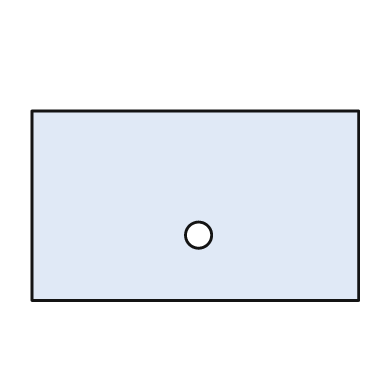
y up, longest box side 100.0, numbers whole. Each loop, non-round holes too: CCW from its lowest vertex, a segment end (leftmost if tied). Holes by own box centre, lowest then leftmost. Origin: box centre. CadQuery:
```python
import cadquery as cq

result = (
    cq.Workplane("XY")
    .moveTo(-50.0, -29.0)
    .lineTo(50.0, -29.0)
    .lineTo(50.0, 29.0)
    .lineTo(-50.0, 29.0)
    .close()
    .moveTo(1.0, -9.0)
    .circle(4.0)
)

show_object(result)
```